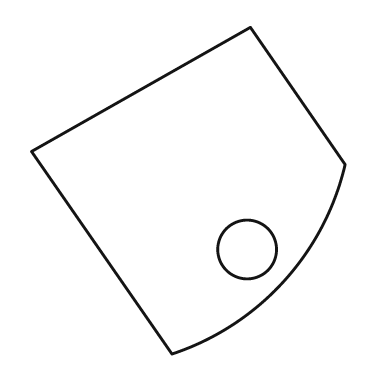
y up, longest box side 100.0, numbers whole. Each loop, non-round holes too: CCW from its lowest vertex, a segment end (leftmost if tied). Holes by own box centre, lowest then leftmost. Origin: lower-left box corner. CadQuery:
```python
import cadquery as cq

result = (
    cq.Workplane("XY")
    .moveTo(43.0, 0.0)
    .threePointArc((77.0, 22.0), (96.0, 58.0))
    .lineTo(67.0, 100.0)
    .lineTo(0.0, 62.0)
    .close()
    .moveTo(66.0, 32.0)
    .circle(9.0)
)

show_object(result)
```